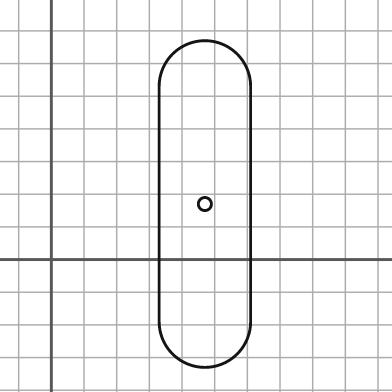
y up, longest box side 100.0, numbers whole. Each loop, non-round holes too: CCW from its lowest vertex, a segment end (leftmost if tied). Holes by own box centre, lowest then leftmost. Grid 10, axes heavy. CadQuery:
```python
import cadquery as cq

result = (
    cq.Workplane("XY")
    .moveTo(33.0, -19.0)
    .threePointArc((47.0, -33.0), (61.0, -19.0))
    .lineTo(61.0, 53.0)
    .threePointArc((47.0, 67.0), (33.0, 53.0))
    .close()
    .moveTo(47.0, 17.0)
    .circle(2.0)
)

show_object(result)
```